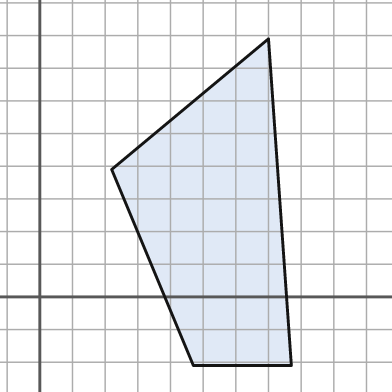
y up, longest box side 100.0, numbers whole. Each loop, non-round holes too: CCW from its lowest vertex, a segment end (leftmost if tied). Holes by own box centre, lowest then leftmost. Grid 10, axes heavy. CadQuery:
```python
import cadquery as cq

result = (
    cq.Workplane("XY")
    .moveTo(47.0, -21.0)
    .lineTo(77.0, -21.0)
    .lineTo(70.0, 79.0)
    .lineTo(22.0, 39.0)
    .close()
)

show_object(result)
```